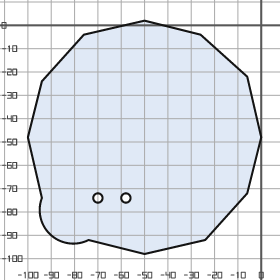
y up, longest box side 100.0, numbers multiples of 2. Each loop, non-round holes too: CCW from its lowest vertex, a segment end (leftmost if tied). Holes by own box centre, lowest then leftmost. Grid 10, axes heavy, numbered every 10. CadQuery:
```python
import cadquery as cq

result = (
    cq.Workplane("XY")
    .moveTo(-50.0, -98.0)
    .lineTo(-24.0, -92.0)
    .lineTo(-6.0, -72.0)
    .lineTo(0.0, -48.0)
    .lineTo(-6.0, -22.0)
    .lineTo(-26.0, -4.0)
    .lineTo(-50.0, 2.0)
    .lineTo(-76.0, -4.0)
    .lineTo(-94.0, -24.0)
    .lineTo(-100.0, -48.0)
    .lineTo(-94.0, -74.0)
    .threePointArc((-90.0, -90.0), (-74.0, -92.0))
    .close()
    .moveTo(-70.0, -74.0)
    .circle(2.0)
    .moveTo(-58.0, -74.0)
    .circle(2.0)
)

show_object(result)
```